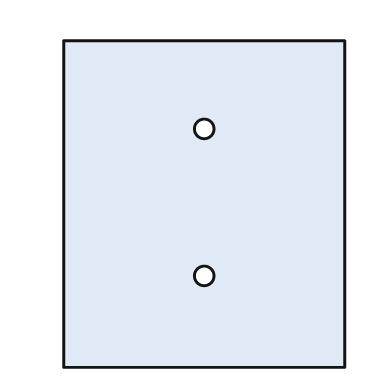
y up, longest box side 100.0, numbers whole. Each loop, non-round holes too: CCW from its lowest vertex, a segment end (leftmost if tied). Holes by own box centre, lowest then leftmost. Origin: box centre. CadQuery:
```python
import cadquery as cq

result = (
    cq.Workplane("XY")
    .moveTo(-43.0, -50.0)
    .lineTo(43.0, -50.0)
    .lineTo(43.0, 50.0)
    .lineTo(-43.0, 50.0)
    .close()
    .moveTo(0.0, -22.0)
    .circle(3.0)
    .moveTo(0.0, 23.0)
    .circle(3.0)
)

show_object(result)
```